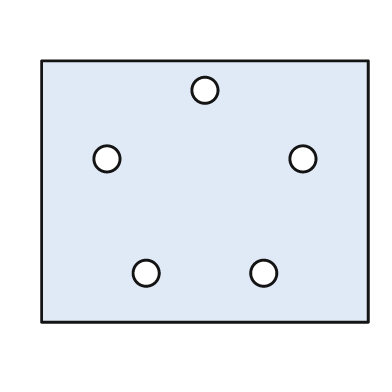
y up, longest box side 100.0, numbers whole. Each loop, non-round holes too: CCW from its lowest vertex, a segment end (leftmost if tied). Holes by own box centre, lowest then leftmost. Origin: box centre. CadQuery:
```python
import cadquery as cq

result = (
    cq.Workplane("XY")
    .moveTo(-50.0, -40.0)
    .lineTo(50.0, -40.0)
    .lineTo(50.0, 40.0)
    .lineTo(-50.0, 40.0)
    .close()
    .moveTo(-18.0, -25.0)
    .circle(4.0)
    .moveTo(18.0, -25.0)
    .circle(4.0)
    .moveTo(-30.0, 10.0)
    .circle(4.0)
    .moveTo(30.0, 10.0)
    .circle(4.0)
    .moveTo(0.0, 31.0)
    .circle(4.0)
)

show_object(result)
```